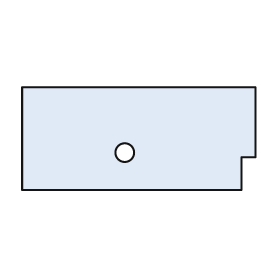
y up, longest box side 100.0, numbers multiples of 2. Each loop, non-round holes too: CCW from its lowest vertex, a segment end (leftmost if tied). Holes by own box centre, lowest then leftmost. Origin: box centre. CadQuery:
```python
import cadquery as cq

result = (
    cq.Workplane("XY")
    .moveTo(-50.0, -22.0)
    .lineTo(44.0, -22.0)
    .lineTo(44.0, -8.0)
    .lineTo(50.0, -8.0)
    .lineTo(50.0, 22.0)
    .lineTo(-50.0, 22.0)
    .close()
    .moveTo(-6.0, -6.0)
    .circle(4.0)
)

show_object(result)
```